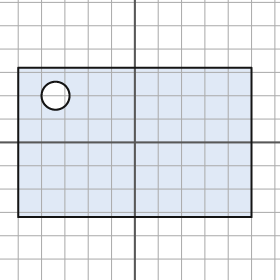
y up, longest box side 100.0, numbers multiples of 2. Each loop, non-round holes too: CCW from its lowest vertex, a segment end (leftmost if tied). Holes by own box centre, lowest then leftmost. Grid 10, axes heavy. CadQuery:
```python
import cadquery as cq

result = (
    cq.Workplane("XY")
    .moveTo(-50.0, -32.0)
    .lineTo(50.0, -32.0)
    .lineTo(50.0, 32.0)
    .lineTo(-50.0, 32.0)
    .close()
    .moveTo(-34.0, 20.0)
    .circle(6.0)
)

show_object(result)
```